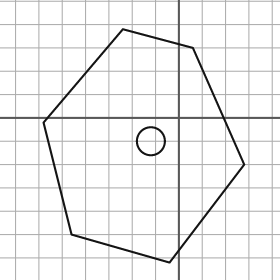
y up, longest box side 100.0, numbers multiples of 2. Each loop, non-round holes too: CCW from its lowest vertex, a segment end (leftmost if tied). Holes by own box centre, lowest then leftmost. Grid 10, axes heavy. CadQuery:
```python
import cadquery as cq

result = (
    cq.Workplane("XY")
    .moveTo(-4.0, -62.0)
    .lineTo(28.0, -20.0)
    .lineTo(6.0, 30.0)
    .lineTo(-24.0, 38.0)
    .lineTo(-58.0, -2.0)
    .lineTo(-46.0, -50.0)
    .close()
    .moveTo(-12.0, -10.0)
    .circle(6.0)
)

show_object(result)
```